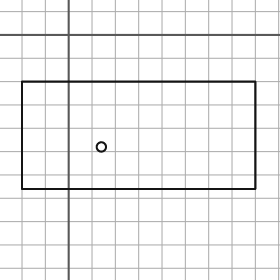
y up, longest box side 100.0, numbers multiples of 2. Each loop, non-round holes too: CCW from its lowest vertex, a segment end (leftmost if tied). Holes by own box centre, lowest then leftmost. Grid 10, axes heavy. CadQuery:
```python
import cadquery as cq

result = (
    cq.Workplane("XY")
    .moveTo(-20.0, -66.0)
    .lineTo(80.0, -66.0)
    .lineTo(80.0, -20.0)
    .lineTo(-20.0, -20.0)
    .close()
    .moveTo(14.0, -48.0)
    .circle(2.0)
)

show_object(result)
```